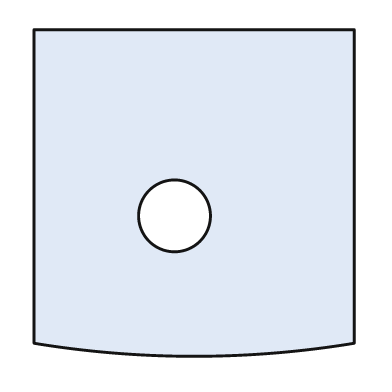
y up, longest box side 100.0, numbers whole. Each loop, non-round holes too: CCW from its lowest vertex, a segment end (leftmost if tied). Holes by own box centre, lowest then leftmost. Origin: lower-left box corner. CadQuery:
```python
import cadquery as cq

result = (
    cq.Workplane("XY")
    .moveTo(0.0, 4.0)
    .threePointArc((49.0, 0.0), (98.0, 4.0))
    .lineTo(98.0, 100.0)
    .lineTo(0.0, 100.0)
    .close()
    .moveTo(43.0, 43.0)
    .circle(11.0)
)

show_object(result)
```